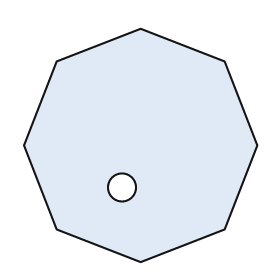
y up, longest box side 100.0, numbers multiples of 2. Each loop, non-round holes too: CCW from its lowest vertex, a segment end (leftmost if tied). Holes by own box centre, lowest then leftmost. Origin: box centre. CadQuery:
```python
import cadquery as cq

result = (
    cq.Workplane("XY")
    .moveTo(0.0, -50.0)
    .lineTo(36.0, -36.0)
    .lineTo(50.0, 0.0)
    .lineTo(36.0, 36.0)
    .lineTo(0.0, 50.0)
    .lineTo(-36.0, 36.0)
    .lineTo(-50.0, 0.0)
    .lineTo(-36.0, -36.0)
    .close()
    .moveTo(-8.0, -18.0)
    .circle(6.0)
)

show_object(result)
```